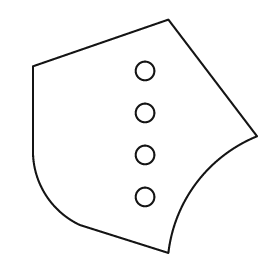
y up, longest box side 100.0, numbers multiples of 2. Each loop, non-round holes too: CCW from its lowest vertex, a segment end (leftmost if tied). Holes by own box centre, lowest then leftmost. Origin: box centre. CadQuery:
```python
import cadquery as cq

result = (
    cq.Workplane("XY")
    .moveTo(10.0, -50.0)
    .threePointArc((22.0, -20.0), (48.0, 0.0))
    .lineTo(10.0, 50.0)
    .lineTo(-48.0, 30.0)
    .lineTo(-48.0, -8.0)
    .threePointArc((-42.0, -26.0), (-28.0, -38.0))
    .close()
    .moveTo(0.0, -26.0)
    .circle(4.0)
    .moveTo(0.0, -8.0)
    .circle(4.0)
    .moveTo(0.0, 10.0)
    .circle(4.0)
    .moveTo(0.0, 28.0)
    .circle(4.0)
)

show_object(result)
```